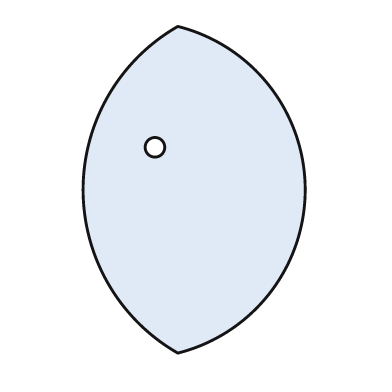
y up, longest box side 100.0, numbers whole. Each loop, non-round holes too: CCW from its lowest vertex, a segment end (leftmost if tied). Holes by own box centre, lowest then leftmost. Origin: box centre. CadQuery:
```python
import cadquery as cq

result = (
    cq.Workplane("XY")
    .moveTo(-5.0, -50.0)
    .threePointArc((34.0, 0.0), (-5.0, 50.0))
    .threePointArc((-34.0, 0.0), (-5.0, -50.0))
    .close()
    .moveTo(-12.0, 13.0)
    .circle(3.0)
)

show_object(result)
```